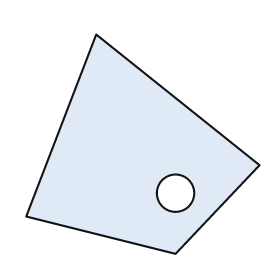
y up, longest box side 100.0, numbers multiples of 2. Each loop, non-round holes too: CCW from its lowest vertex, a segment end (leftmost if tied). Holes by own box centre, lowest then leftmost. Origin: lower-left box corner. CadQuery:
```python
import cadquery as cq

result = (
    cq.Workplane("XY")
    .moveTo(64.0, 0.0)
    .lineTo(100.0, 38.0)
    .lineTo(30.0, 94.0)
    .lineTo(0.0, 16.0)
    .close()
    .moveTo(64.0, 26.0)
    .circle(8.0)
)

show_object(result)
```